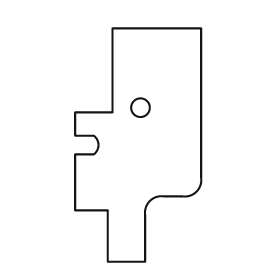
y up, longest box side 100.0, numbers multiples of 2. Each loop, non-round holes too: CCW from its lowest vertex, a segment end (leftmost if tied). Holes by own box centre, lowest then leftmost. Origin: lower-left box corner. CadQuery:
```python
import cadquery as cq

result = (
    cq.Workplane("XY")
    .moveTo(14.0, 0.0)
    .lineTo(30.0, 0.0)
    .lineTo(30.0, 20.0)
    .threePointArc((32.0, 26.0), (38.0, 28.0))
    .lineTo(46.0, 28.0)
    .threePointArc((52.0, 30.0), (54.0, 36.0))
    .lineTo(54.0, 100.0)
    .lineTo(16.0, 100.0)
    .lineTo(16.0, 64.0)
    .lineTo(0.0, 64.0)
    .lineTo(0.0, 54.0)
    .lineTo(8.0, 54.0)
    .threePointArc((10.0, 50.0), (8.0, 46.0))
    .lineTo(0.0, 46.0)
    .lineTo(0.0, 22.0)
    .lineTo(14.0, 22.0)
    .close()
    .moveTo(28.0, 66.0)
    .circle(4.0)
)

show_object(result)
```